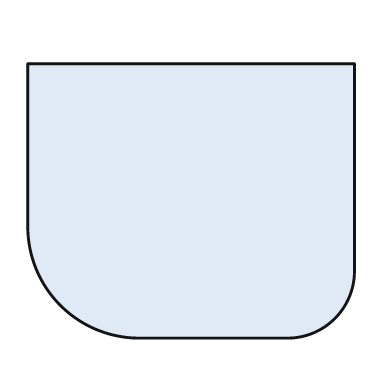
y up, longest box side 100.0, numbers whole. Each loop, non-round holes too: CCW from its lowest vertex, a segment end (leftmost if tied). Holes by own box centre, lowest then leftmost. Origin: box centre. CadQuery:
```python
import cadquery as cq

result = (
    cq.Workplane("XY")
    .moveTo(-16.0, -42.0)
    .lineTo(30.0, -42.0)
    .threePointArc((44.0, -36.0), (50.0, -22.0))
    .lineTo(50.0, 42.0)
    .lineTo(-50.0, 42.0)
    .lineTo(-50.0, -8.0)
    .threePointArc((-40.0, -32.0), (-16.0, -42.0))
    .close()
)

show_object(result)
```